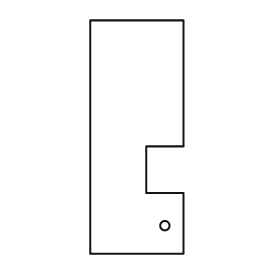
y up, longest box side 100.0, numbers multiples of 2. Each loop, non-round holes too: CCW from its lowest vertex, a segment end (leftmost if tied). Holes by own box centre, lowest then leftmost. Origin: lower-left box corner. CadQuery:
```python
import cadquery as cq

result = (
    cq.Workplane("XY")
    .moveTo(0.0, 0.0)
    .lineTo(40.0, 0.0)
    .lineTo(40.0, 26.0)
    .lineTo(24.0, 26.0)
    .lineTo(24.0, 46.0)
    .lineTo(40.0, 46.0)
    .lineTo(40.0, 100.0)
    .lineTo(0.0, 100.0)
    .close()
    .moveTo(32.0, 12.0)
    .circle(2.0)
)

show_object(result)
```